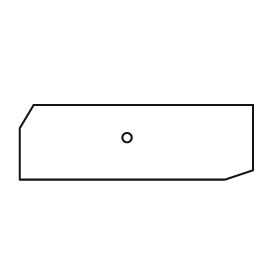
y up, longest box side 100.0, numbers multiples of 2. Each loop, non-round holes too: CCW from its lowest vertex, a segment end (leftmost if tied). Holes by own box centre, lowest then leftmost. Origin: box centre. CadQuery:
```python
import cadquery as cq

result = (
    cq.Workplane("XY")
    .moveTo(-50.0, -16.0)
    .lineTo(38.0, -16.0)
    .lineTo(50.0, -12.0)
    .lineTo(50.0, 16.0)
    .lineTo(-44.0, 16.0)
    .lineTo(-50.0, 6.0)
    .close()
    .moveTo(-4.0, 2.0)
    .circle(2.0)
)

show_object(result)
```